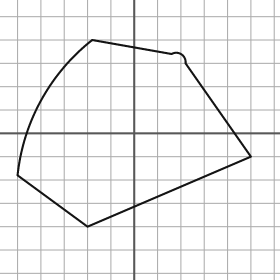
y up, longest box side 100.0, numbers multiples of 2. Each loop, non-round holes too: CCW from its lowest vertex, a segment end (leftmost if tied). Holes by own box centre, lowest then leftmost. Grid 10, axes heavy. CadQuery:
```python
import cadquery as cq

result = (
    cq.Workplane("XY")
    .moveTo(-20.0, -40.0)
    .lineTo(50.0, -10.0)
    .lineTo(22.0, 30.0)
    .threePointArc((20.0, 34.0), (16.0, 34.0))
    .lineTo(-18.0, 40.0)
    .threePointArc((-40.0, 14.0), (-50.0, -18.0))
    .close()
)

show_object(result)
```